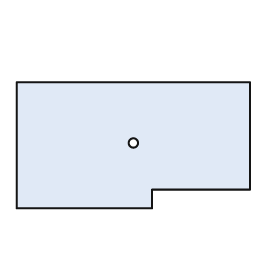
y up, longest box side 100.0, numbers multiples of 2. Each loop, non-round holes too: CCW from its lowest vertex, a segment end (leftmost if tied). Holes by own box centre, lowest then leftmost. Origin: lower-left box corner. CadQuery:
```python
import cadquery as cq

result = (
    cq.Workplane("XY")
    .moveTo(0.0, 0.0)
    .lineTo(58.0, 0.0)
    .lineTo(58.0, 8.0)
    .lineTo(100.0, 8.0)
    .lineTo(100.0, 54.0)
    .lineTo(0.0, 54.0)
    .close()
    .moveTo(50.0, 28.0)
    .circle(2.0)
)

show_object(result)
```